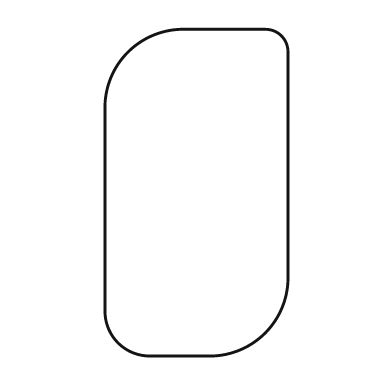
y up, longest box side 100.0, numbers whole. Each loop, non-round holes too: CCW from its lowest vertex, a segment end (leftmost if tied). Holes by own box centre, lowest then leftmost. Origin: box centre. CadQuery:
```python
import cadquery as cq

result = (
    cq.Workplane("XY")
    .moveTo(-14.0, -50.0)
    .lineTo(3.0, -50.0)
    .threePointArc((21.0, -43.0), (28.0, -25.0))
    .lineTo(28.0, 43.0)
    .threePointArc((26.0, 48.0), (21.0, 50.0))
    .lineTo(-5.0, 50.0)
    .threePointArc((-21.0, 43.0), (-28.0, 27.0))
    .lineTo(-28.0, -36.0)
    .threePointArc((-24.0, -46.0), (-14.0, -50.0))
    .close()
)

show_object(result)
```